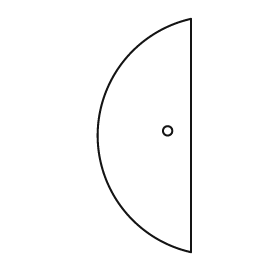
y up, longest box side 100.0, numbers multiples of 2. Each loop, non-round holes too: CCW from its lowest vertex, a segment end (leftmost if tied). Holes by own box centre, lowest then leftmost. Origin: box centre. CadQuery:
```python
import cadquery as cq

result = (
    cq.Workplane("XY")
    .moveTo(20.0, -50.0)
    .lineTo(20.0, 50.0)
    .threePointArc((-20.0, 0.0), (20.0, -50.0))
    .close()
    .moveTo(10.0, 2.0)
    .circle(2.0)
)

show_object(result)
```